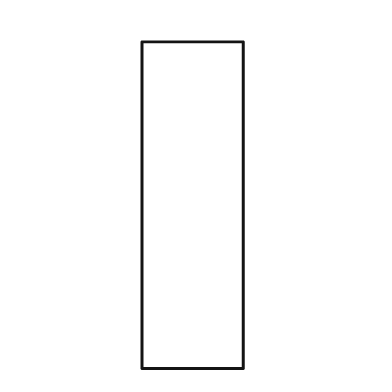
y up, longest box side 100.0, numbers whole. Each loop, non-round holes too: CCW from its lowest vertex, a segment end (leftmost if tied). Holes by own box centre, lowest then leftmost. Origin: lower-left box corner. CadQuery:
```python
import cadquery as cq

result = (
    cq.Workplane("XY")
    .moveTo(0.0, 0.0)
    .lineTo(31.0, 0.0)
    .lineTo(31.0, 100.0)
    .lineTo(0.0, 100.0)
    .close()
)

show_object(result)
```